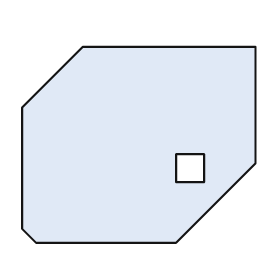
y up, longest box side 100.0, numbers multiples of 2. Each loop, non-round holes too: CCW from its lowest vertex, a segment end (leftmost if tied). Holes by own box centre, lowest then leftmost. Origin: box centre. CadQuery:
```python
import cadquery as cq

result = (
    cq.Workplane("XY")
    .moveTo(-44.0, -42.0)
    .lineTo(16.0, -42.0)
    .lineTo(50.0, -8.0)
    .lineTo(50.0, 42.0)
    .lineTo(-24.0, 42.0)
    .lineTo(-50.0, 16.0)
    .lineTo(-50.0, -36.0)
    .close()
    .moveTo(16.0, -16.0)
    .lineTo(28.0, -16.0)
    .lineTo(28.0, -4.0)
    .lineTo(16.0, -4.0)
    .close()
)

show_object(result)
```